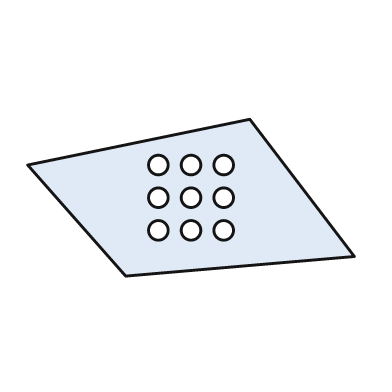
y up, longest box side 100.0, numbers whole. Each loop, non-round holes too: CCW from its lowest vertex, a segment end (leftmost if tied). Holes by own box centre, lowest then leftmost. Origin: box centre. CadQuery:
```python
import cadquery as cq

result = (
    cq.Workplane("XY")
    .moveTo(-20.0, -24.0)
    .lineTo(50.0, -18.0)
    .lineTo(18.0, 24.0)
    .lineTo(-50.0, 10.0)
    .close()
    .moveTo(-10.0, -10.0)
    .circle(3.0)
    .moveTo(0.0, -10.0)
    .circle(3.0)
    .moveTo(10.0, -10.0)
    .circle(3.0)
    .moveTo(-10.0, 0.0)
    .circle(3.0)
    .moveTo(0.0, 0.0)
    .circle(3.0)
    .moveTo(10.0, 0.0)
    .circle(3.0)
    .moveTo(-10.0, 10.0)
    .circle(3.0)
    .moveTo(0.0, 10.0)
    .circle(3.0)
    .moveTo(10.0, 10.0)
    .circle(3.0)
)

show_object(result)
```